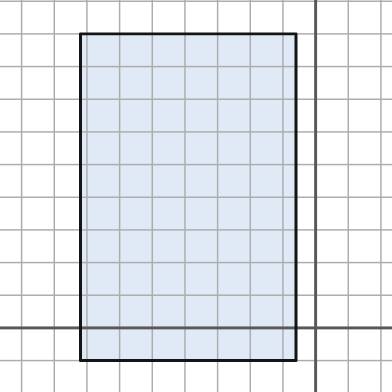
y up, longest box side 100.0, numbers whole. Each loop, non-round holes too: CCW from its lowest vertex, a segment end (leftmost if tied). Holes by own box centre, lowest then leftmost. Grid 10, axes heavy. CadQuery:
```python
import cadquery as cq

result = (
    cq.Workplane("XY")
    .moveTo(-72.0, -10.0)
    .lineTo(-6.0, -10.0)
    .lineTo(-6.0, 90.0)
    .lineTo(-72.0, 90.0)
    .close()
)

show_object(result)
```